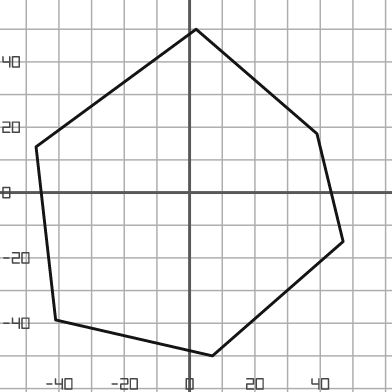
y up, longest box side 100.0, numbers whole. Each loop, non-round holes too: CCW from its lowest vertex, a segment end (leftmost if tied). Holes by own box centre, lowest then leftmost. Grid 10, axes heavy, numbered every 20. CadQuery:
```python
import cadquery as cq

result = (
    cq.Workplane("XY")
    .moveTo(7.0, -50.0)
    .lineTo(47.0, -15.0)
    .lineTo(39.0, 18.0)
    .lineTo(2.0, 50.0)
    .lineTo(-47.0, 14.0)
    .lineTo(-41.0, -39.0)
    .close()
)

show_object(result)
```